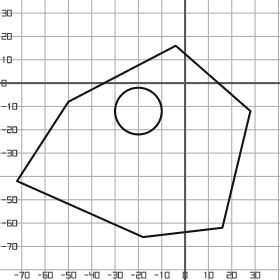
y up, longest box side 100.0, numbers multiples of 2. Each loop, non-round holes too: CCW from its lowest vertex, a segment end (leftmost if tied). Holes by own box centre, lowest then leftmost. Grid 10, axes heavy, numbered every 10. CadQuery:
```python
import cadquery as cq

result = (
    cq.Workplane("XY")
    .moveTo(-18.0, -66.0)
    .lineTo(16.0, -62.0)
    .lineTo(28.0, -12.0)
    .lineTo(-4.0, 16.0)
    .lineTo(-50.0, -8.0)
    .lineTo(-72.0, -42.0)
    .close()
    .moveTo(-20.0, -12.0)
    .circle(10.0)
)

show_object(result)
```